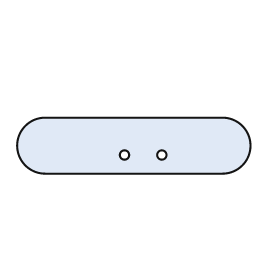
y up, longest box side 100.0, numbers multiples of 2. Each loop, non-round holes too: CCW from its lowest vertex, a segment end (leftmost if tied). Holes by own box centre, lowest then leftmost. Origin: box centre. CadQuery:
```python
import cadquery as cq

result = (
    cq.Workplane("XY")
    .moveTo(-38.0, -12.0)
    .lineTo(38.0, -12.0)
    .threePointArc((50.0, 0.0), (38.0, 12.0))
    .lineTo(-38.0, 12.0)
    .threePointArc((-50.0, 0.0), (-38.0, -12.0))
    .close()
    .moveTo(-4.0, -4.0)
    .circle(2.0)
    .moveTo(12.0, -4.0)
    .circle(2.0)
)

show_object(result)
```